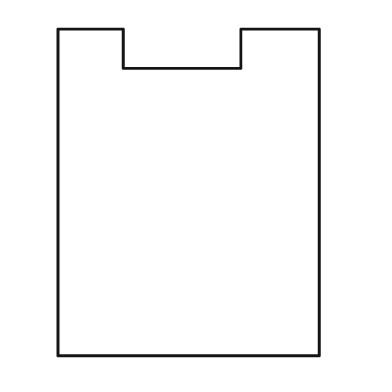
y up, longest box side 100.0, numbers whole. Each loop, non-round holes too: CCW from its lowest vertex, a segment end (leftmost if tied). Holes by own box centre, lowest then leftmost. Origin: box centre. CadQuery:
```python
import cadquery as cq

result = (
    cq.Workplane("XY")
    .moveTo(-40.0, -50.0)
    .lineTo(40.0, -50.0)
    .lineTo(40.0, 50.0)
    .lineTo(16.0, 50.0)
    .lineTo(16.0, 38.0)
    .lineTo(-20.0, 38.0)
    .lineTo(-20.0, 50.0)
    .lineTo(-40.0, 50.0)
    .close()
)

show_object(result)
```